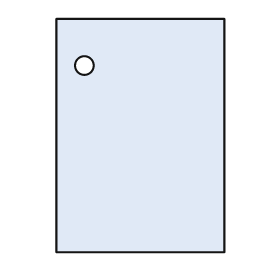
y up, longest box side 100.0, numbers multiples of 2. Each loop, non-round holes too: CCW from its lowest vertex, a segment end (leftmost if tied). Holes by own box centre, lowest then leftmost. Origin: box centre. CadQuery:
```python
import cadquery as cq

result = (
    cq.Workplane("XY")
    .moveTo(-36.0, -50.0)
    .lineTo(36.0, -50.0)
    .lineTo(36.0, 50.0)
    .lineTo(-36.0, 50.0)
    .close()
    .moveTo(-24.0, 30.0)
    .circle(4.0)
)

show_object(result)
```